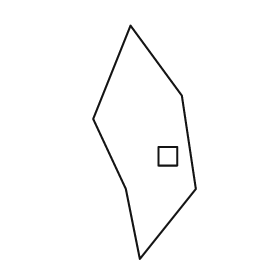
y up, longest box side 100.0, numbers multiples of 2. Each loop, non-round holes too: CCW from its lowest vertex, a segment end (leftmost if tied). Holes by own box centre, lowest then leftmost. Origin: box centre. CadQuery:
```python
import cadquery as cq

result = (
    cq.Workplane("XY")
    .moveTo(-2.0, -50.0)
    .lineTo(22.0, -20.0)
    .lineTo(16.0, 20.0)
    .lineTo(-6.0, 50.0)
    .lineTo(-22.0, 10.0)
    .lineTo(-8.0, -20.0)
    .close()
    .moveTo(6.0, -10.0)
    .lineTo(14.0, -10.0)
    .lineTo(14.0, -2.0)
    .lineTo(6.0, -2.0)
    .close()
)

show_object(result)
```